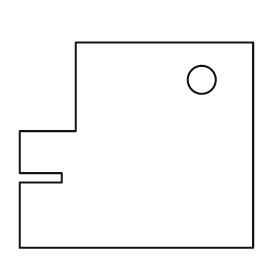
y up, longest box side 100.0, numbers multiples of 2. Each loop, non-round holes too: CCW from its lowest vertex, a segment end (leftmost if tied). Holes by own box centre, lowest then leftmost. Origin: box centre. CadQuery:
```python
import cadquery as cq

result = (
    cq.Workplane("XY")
    .moveTo(-50.0, -44.0)
    .lineTo(50.0, -44.0)
    .lineTo(50.0, 44.0)
    .lineTo(-26.0, 44.0)
    .lineTo(-26.0, 6.0)
    .lineTo(-50.0, 6.0)
    .lineTo(-50.0, -12.0)
    .lineTo(-32.0, -12.0)
    .lineTo(-32.0, -16.0)
    .lineTo(-50.0, -16.0)
    .close()
    .moveTo(28.0, 28.0)
    .circle(6.0)
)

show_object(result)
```